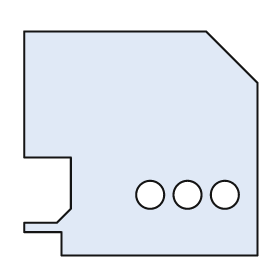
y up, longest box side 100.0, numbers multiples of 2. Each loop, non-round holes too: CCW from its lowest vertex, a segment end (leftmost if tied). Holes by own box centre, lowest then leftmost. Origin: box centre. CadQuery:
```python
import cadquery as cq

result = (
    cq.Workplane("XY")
    .moveTo(-34.0, -48.0)
    .lineTo(50.0, -48.0)
    .lineTo(50.0, 26.0)
    .lineTo(28.0, 48.0)
    .lineTo(-50.0, 48.0)
    .lineTo(-50.0, -6.0)
    .lineTo(-30.0, -6.0)
    .lineTo(-30.0, -28.0)
    .lineTo(-36.0, -34.0)
    .lineTo(-50.0, -34.0)
    .lineTo(-50.0, -38.0)
    .lineTo(-34.0, -38.0)
    .close()
    .moveTo(4.0, -22.0)
    .circle(6.0)
    .moveTo(20.0, -22.0)
    .circle(6.0)
    .moveTo(36.0, -22.0)
    .circle(6.0)
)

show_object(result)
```